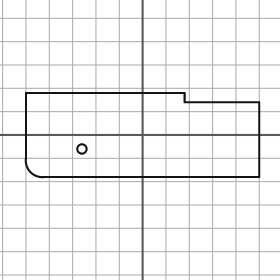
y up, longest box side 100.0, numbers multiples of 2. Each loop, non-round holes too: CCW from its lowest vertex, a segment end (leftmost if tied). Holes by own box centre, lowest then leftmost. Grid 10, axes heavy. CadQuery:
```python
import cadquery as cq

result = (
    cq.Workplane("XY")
    .moveTo(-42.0, -18.0)
    .lineTo(50.0, -18.0)
    .lineTo(50.0, 14.0)
    .lineTo(18.0, 14.0)
    .lineTo(18.0, 18.0)
    .lineTo(-50.0, 18.0)
    .lineTo(-50.0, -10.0)
    .threePointArc((-48.0, -16.0), (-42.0, -18.0))
    .close()
    .moveTo(-26.0, -6.0)
    .circle(2.0)
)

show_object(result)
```